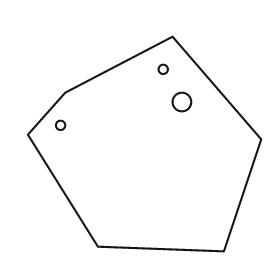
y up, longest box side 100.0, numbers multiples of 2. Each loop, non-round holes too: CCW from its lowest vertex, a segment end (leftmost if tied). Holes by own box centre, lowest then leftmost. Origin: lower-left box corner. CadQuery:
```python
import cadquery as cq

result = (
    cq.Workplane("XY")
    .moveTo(84.0, 0.0)
    .lineTo(100.0, 48.0)
    .lineTo(62.0, 92.0)
    .lineTo(16.0, 68.0)
    .lineTo(0.0, 50.0)
    .lineTo(30.0, 2.0)
    .close()
    .moveTo(14.0, 54.0)
    .circle(2.0)
    .moveTo(66.0, 64.0)
    .circle(4.0)
    .moveTo(58.0, 78.0)
    .circle(2.0)
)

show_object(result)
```